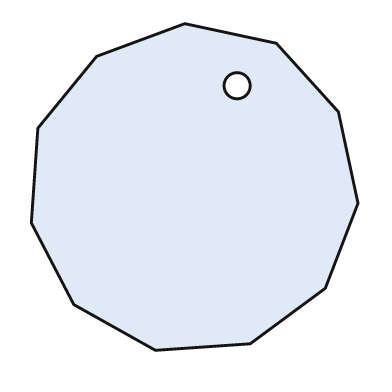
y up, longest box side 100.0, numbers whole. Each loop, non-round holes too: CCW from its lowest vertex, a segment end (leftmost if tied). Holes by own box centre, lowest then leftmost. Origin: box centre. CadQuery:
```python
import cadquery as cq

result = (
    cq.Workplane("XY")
    .moveTo(-12.0, -50.0)
    .lineTo(17.0, -48.0)
    .lineTo(40.0, -31.0)
    .lineTo(50.0, -5.0)
    .lineTo(44.0, 23.0)
    .lineTo(25.0, 44.0)
    .lineTo(-3.0, 50.0)
    .lineTo(-30.0, 40.0)
    .lineTo(-48.0, 18.0)
    .lineTo(-50.0, -11.0)
    .lineTo(-37.0, -36.0)
    .close()
    .moveTo(13.0, 31.0)
    .circle(4.0)
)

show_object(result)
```